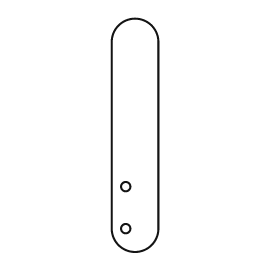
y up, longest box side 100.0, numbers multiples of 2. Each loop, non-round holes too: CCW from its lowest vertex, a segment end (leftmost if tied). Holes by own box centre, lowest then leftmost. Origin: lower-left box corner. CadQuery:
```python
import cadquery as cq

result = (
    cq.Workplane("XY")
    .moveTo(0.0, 10.0)
    .threePointArc((10.0, 0.0), (20.0, 10.0))
    .lineTo(20.0, 90.0)
    .threePointArc((10.0, 100.0), (0.0, 90.0))
    .close()
    .moveTo(6.0, 10.0)
    .circle(2.0)
    .moveTo(6.0, 28.0)
    .circle(2.0)
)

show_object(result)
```